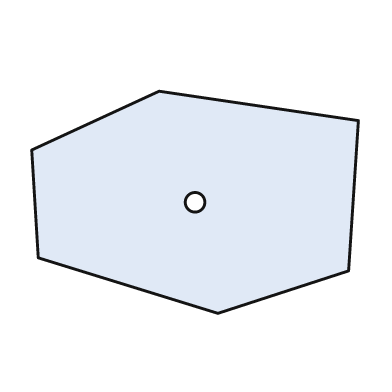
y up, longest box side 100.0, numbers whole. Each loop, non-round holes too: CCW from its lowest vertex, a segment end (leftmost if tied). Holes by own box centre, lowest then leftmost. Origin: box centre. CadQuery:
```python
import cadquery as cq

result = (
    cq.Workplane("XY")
    .moveTo(7.0, -34.0)
    .lineTo(47.0, -21.0)
    .lineTo(50.0, 25.0)
    .lineTo(-11.0, 34.0)
    .lineTo(-50.0, 16.0)
    .lineTo(-48.0, -17.0)
    .close()
    .moveTo(0.0, 0.0)
    .circle(3.0)
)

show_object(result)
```